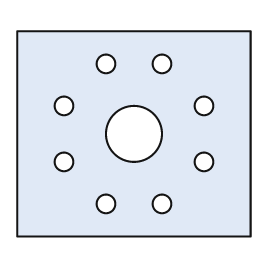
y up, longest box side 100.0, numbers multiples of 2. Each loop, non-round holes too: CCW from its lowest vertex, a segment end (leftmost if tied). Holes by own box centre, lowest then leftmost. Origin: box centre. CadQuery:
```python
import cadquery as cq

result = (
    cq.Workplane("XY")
    .moveTo(-50.0, -44.0)
    .lineTo(50.0, -44.0)
    .lineTo(50.0, 44.0)
    .lineTo(-50.0, 44.0)
    .close()
    .moveTo(-12.0, -30.0)
    .circle(4.0)
    .moveTo(12.0, -30.0)
    .circle(4.0)
    .moveTo(-30.0, -12.0)
    .circle(4.0)
    .moveTo(30.0, -12.0)
    .circle(4.0)
    .moveTo(0.0, 0.0)
    .circle(12.0)
    .moveTo(-30.0, 12.0)
    .circle(4.0)
    .moveTo(30.0, 12.0)
    .circle(4.0)
    .moveTo(-12.0, 30.0)
    .circle(4.0)
    .moveTo(12.0, 30.0)
    .circle(4.0)
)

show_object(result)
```